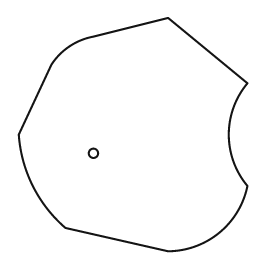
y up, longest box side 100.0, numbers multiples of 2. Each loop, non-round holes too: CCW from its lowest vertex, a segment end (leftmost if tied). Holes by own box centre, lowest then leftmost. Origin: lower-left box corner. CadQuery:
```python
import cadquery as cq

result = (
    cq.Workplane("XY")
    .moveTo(64.0, 0.0)
    .threePointArc((86.0, 8.0), (98.0, 28.0))
    .threePointArc((90.0, 50.0), (98.0, 72.0))
    .lineTo(64.0, 100.0)
    .lineTo(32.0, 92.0)
    .threePointArc((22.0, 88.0), (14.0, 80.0))
    .lineTo(0.0, 50.0)
    .threePointArc((6.0, 28.0), (20.0, 10.0))
    .close()
    .moveTo(32.0, 42.0)
    .circle(2.0)
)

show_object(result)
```